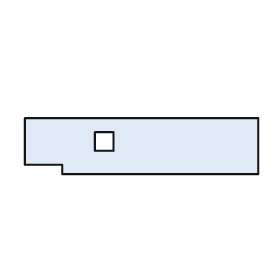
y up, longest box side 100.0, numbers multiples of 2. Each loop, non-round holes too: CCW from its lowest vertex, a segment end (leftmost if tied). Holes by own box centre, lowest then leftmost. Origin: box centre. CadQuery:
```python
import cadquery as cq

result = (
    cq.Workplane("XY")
    .moveTo(-34.0, -12.0)
    .lineTo(50.0, -12.0)
    .lineTo(50.0, 12.0)
    .lineTo(-50.0, 12.0)
    .lineTo(-50.0, -8.0)
    .lineTo(-34.0, -8.0)
    .close()
    .moveTo(-20.0, -2.0)
    .lineTo(-12.0, -2.0)
    .lineTo(-12.0, 6.0)
    .lineTo(-20.0, 6.0)
    .close()
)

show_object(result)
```